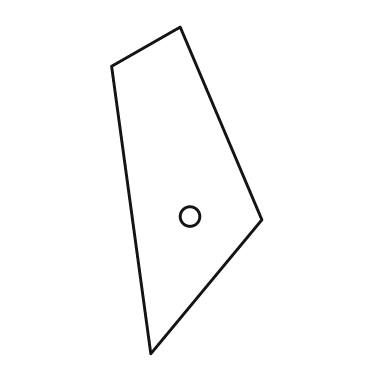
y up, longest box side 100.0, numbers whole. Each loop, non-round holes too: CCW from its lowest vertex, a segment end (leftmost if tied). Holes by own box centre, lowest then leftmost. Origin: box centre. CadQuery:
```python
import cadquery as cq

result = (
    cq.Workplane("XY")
    .moveTo(-11.0, -50.0)
    .lineTo(23.0, -9.0)
    .lineTo(-2.0, 50.0)
    .lineTo(-23.0, 38.0)
    .close()
    .moveTo(1.0, -8.0)
    .circle(3.0)
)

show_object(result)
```